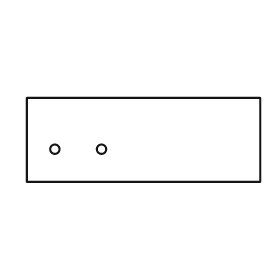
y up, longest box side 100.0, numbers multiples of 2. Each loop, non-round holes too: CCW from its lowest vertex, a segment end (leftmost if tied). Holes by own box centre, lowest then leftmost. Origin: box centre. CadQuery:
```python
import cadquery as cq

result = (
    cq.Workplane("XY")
    .moveTo(-50.0, -18.0)
    .lineTo(50.0, -18.0)
    .lineTo(50.0, 18.0)
    .lineTo(-50.0, 18.0)
    .close()
    .moveTo(-38.0, -4.0)
    .circle(2.0)
    .moveTo(-18.0, -4.0)
    .circle(2.0)
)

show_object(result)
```